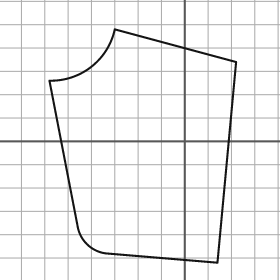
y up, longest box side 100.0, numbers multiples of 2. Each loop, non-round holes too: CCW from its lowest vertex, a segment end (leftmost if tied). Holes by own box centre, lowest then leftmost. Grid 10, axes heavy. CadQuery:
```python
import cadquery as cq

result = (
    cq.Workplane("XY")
    .moveTo(14.0, -52.0)
    .lineTo(22.0, 34.0)
    .lineTo(-30.0, 48.0)
    .threePointArc((-40.0, 32.0), (-58.0, 26.0))
    .lineTo(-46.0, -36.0)
    .threePointArc((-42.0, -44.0), (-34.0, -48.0))
    .close()
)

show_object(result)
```